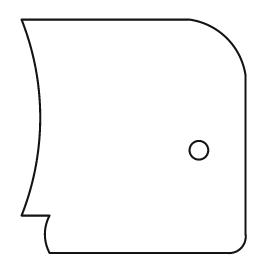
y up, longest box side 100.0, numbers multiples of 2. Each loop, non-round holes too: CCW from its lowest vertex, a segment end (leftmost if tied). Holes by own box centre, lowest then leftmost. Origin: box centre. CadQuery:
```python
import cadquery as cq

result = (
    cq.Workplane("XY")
    .moveTo(-36.0, -50.0)
    .lineTo(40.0, -50.0)
    .threePointArc((46.0, -48.0), (48.0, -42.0))
    .lineTo(48.0, 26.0)
    .threePointArc((40.0, 42.0), (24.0, 50.0))
    .lineTo(-48.0, 50.0)
    .threePointArc((-40.0, 8.0), (-48.0, -34.0))
    .lineTo(-36.0, -34.0)
    .threePointArc((-38.0, -42.0), (-36.0, -50.0))
    .close()
    .moveTo(28.0, -6.0)
    .circle(4.0)
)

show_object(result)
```